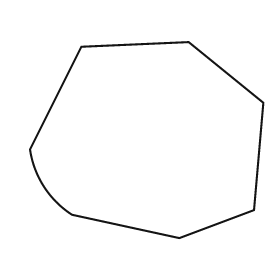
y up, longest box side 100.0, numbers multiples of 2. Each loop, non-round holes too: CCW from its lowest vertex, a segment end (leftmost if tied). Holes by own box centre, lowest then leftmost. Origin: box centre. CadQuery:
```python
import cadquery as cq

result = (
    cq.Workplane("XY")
    .moveTo(14.0, -42.0)
    .lineTo(46.0, -30.0)
    .lineTo(50.0, 16.0)
    .lineTo(18.0, 42.0)
    .lineTo(-28.0, 40.0)
    .lineTo(-50.0, -4.0)
    .threePointArc((-44.0, -20.0), (-32.0, -32.0))
    .close()
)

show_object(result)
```